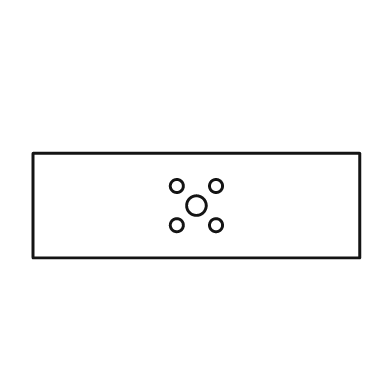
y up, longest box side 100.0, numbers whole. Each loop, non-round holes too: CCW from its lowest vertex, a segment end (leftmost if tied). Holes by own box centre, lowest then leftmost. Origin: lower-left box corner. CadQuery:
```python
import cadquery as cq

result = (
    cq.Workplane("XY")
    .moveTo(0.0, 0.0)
    .lineTo(100.0, 0.0)
    .lineTo(100.0, 32.0)
    .lineTo(0.0, 32.0)
    .close()
    .moveTo(44.0, 10.0)
    .circle(2.0)
    .moveTo(56.0, 10.0)
    .circle(2.0)
    .moveTo(50.0, 16.0)
    .circle(3.0)
    .moveTo(44.0, 22.0)
    .circle(2.0)
    .moveTo(56.0, 22.0)
    .circle(2.0)
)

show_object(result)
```